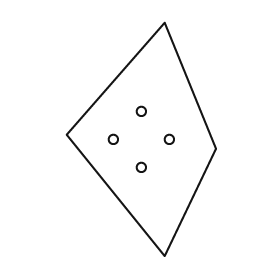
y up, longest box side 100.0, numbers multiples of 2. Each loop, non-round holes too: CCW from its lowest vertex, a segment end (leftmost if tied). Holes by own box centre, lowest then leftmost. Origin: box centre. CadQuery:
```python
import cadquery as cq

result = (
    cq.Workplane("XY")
    .moveTo(10.0, -50.0)
    .lineTo(32.0, -4.0)
    .lineTo(10.0, 50.0)
    .lineTo(-32.0, 2.0)
    .close()
    .moveTo(0.0, -12.0)
    .circle(2.0)
    .moveTo(-12.0, 0.0)
    .circle(2.0)
    .moveTo(12.0, 0.0)
    .circle(2.0)
    .moveTo(0.0, 12.0)
    .circle(2.0)
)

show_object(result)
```